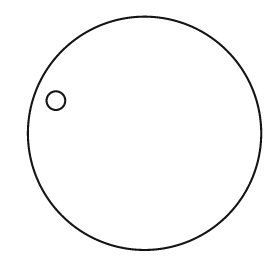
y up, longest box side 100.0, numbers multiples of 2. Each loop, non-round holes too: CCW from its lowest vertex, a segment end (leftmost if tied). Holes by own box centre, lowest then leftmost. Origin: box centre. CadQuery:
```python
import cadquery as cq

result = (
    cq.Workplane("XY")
    .moveTo(0.0, 0.0)
    .circle(50.0)
    .moveTo(-38.0, 14.0)
    .circle(4.0)
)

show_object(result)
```